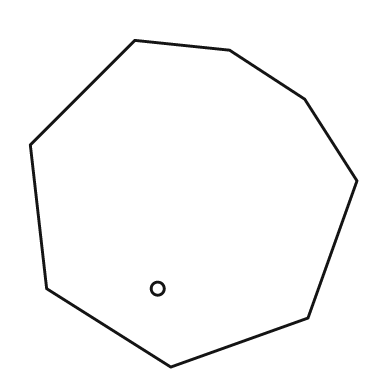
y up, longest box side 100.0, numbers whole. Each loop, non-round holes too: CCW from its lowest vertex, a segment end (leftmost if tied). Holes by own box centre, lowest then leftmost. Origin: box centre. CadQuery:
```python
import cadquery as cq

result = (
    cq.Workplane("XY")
    .moveTo(-7.0, -50.0)
    .lineTo(35.0, -35.0)
    .lineTo(50.0, 7.0)
    .lineTo(34.0, 32.0)
    .lineTo(11.0, 47.0)
    .lineTo(-18.0, 50.0)
    .lineTo(-50.0, 18.0)
    .lineTo(-45.0, -26.0)
    .close()
    .moveTo(-11.0, -26.0)
    .circle(2.0)
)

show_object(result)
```